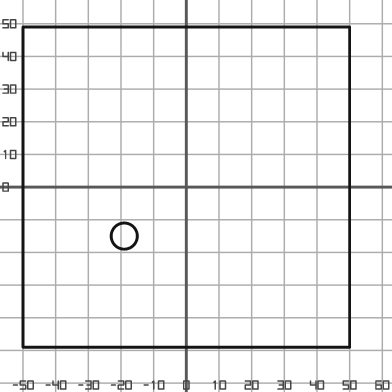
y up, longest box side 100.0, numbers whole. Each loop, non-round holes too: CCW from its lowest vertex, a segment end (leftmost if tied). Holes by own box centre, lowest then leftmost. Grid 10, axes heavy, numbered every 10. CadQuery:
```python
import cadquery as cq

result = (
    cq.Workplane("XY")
    .moveTo(-50.0, -49.0)
    .lineTo(50.0, -49.0)
    .lineTo(50.0, 49.0)
    .lineTo(-50.0, 49.0)
    .close()
    .moveTo(-19.0, -15.0)
    .circle(4.0)
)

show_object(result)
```